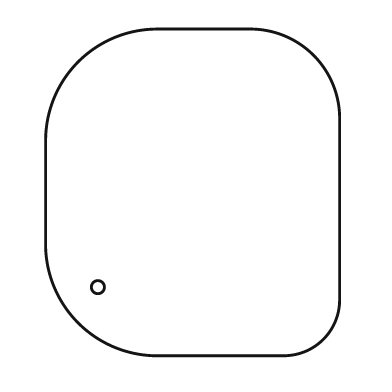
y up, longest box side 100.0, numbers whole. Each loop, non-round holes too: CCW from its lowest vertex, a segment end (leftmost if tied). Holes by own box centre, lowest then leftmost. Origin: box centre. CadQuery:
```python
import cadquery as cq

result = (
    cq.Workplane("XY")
    .moveTo(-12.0, -50.0)
    .lineTo(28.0, -50.0)
    .threePointArc((40.0, -45.0), (45.0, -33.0))
    .lineTo(45.0, 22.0)
    .threePointArc((37.0, 42.0), (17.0, 50.0))
    .lineTo(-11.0, 50.0)
    .threePointArc((-35.0, 40.0), (-45.0, 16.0))
    .lineTo(-45.0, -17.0)
    .threePointArc((-35.0, -40.0), (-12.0, -50.0))
    .close()
    .moveTo(-29.0, -29.0)
    .circle(2.0)
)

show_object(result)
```